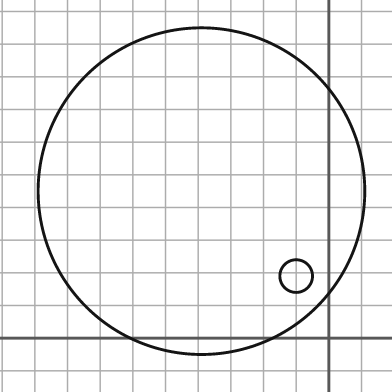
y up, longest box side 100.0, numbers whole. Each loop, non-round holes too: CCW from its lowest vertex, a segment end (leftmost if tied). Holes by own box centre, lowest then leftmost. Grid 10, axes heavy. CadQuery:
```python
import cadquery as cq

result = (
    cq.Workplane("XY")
    .moveTo(-39.0, 45.0)
    .circle(50.0)
    .moveTo(-10.0, 19.0)
    .circle(5.0)
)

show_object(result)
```